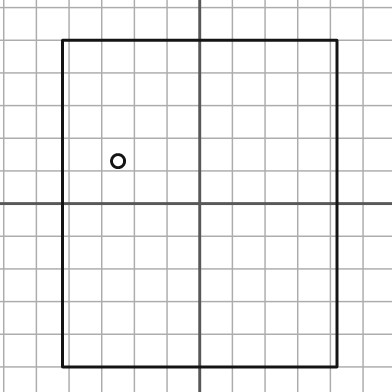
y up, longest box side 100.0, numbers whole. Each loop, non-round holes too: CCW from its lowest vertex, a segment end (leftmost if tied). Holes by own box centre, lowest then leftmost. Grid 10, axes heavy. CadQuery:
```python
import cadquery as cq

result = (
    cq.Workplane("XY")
    .moveTo(-42.0, -50.0)
    .lineTo(42.0, -50.0)
    .lineTo(42.0, 50.0)
    .lineTo(-42.0, 50.0)
    .close()
    .moveTo(-25.0, 13.0)
    .circle(2.0)
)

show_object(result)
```